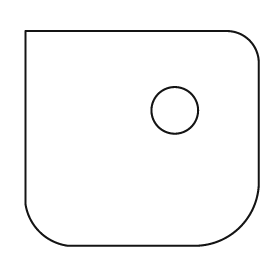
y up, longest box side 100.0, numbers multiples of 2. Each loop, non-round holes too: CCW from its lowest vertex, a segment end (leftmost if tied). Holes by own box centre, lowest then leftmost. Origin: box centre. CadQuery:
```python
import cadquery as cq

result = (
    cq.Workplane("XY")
    .moveTo(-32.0, -46.0)
    .lineTo(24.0, -46.0)
    .threePointArc((42.0, -38.0), (50.0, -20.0))
    .lineTo(50.0, 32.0)
    .threePointArc((46.0, 42.0), (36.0, 46.0))
    .lineTo(-50.0, 46.0)
    .lineTo(-50.0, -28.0)
    .threePointArc((-44.0, -40.0), (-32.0, -46.0))
    .close()
    .moveTo(14.0, 12.0)
    .circle(10.0)
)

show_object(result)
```